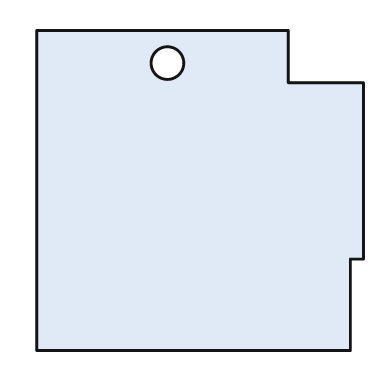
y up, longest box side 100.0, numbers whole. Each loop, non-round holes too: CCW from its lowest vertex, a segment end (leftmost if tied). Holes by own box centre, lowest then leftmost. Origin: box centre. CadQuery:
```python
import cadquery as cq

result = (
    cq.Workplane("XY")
    .moveTo(-50.0, -49.0)
    .lineTo(46.0, -49.0)
    .lineTo(46.0, -21.0)
    .lineTo(50.0, -21.0)
    .lineTo(50.0, 33.0)
    .lineTo(27.0, 33.0)
    .lineTo(27.0, 49.0)
    .lineTo(-50.0, 49.0)
    .close()
    .moveTo(-10.0, 39.0)
    .circle(5.0)
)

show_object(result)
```